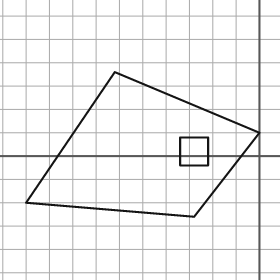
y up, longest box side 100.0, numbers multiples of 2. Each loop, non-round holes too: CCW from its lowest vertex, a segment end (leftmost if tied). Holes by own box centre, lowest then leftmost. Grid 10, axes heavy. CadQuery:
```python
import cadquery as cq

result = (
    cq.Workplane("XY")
    .moveTo(-28.0, -26.0)
    .lineTo(0.0, 10.0)
    .lineTo(-62.0, 36.0)
    .lineTo(-100.0, -20.0)
    .close()
    .moveTo(-34.0, -4.0)
    .lineTo(-22.0, -4.0)
    .lineTo(-22.0, 8.0)
    .lineTo(-34.0, 8.0)
    .close()
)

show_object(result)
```